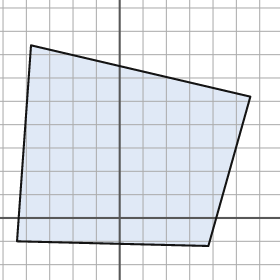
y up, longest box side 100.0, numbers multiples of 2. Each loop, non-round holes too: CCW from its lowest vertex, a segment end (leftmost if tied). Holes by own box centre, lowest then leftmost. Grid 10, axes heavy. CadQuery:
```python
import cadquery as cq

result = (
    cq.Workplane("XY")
    .moveTo(38.0, -12.0)
    .lineTo(56.0, 52.0)
    .lineTo(-38.0, 74.0)
    .lineTo(-44.0, -10.0)
    .close()
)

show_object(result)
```